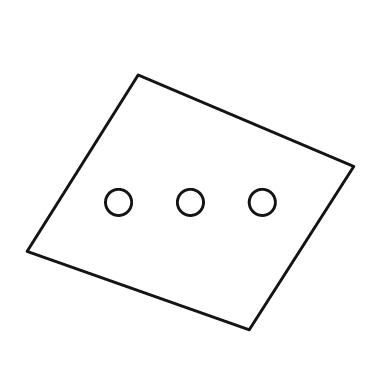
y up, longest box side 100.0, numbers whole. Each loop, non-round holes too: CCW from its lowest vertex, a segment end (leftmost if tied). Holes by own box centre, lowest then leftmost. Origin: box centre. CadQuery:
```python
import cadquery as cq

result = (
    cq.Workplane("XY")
    .moveTo(18.0, -39.0)
    .lineTo(50.0, 11.0)
    .lineTo(-16.0, 39.0)
    .lineTo(-50.0, -15.0)
    .close()
    .moveTo(-22.0, 0.0)
    .circle(4.0)
    .moveTo(0.0, 0.0)
    .circle(4.0)
    .moveTo(22.0, 0.0)
    .circle(4.0)
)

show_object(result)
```